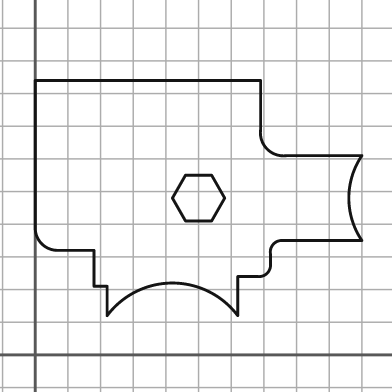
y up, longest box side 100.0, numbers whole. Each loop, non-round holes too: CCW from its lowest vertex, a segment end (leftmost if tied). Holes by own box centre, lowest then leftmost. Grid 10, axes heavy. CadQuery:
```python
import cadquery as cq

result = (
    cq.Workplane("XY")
    .moveTo(22.0, 12.0)
    .threePointArc((42.0, 22.0), (62.0, 12.0))
    .lineTo(62.0, 24.0)
    .lineTo(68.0, 24.0)
    .threePointArc((71.0, 25.0), (72.0, 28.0))
    .lineTo(72.0, 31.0)
    .threePointArc((73.0, 34.0), (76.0, 35.0))
    .lineTo(100.0, 35.0)
    .threePointArc((96.0, 48.0), (100.0, 61.0))
    .lineTo(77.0, 61.0)
    .threePointArc((71.0, 63.0), (69.0, 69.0))
    .lineTo(69.0, 84.0)
    .lineTo(0.0, 84.0)
    .lineTo(0.0, 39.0)
    .threePointArc((2.0, 34.0), (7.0, 32.0))
    .lineTo(18.0, 32.0)
    .lineTo(18.0, 21.0)
    .lineTo(22.0, 21.0)
    .close()
    .moveTo(46.0, 41.0)
    .lineTo(54.0, 41.0)
    .lineTo(58.0, 48.0)
    .lineTo(54.0, 55.0)
    .lineTo(46.0, 55.0)
    .lineTo(42.0, 48.0)
    .close()
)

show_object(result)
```